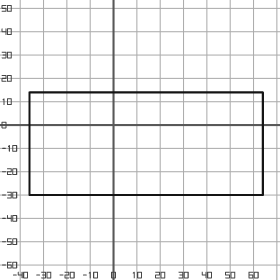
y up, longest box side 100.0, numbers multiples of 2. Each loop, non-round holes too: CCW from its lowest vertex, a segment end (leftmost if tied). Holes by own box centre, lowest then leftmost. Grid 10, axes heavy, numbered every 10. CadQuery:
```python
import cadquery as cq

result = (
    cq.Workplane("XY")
    .moveTo(-36.0, -30.0)
    .lineTo(64.0, -30.0)
    .lineTo(64.0, 14.0)
    .lineTo(-36.0, 14.0)
    .close()
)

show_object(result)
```